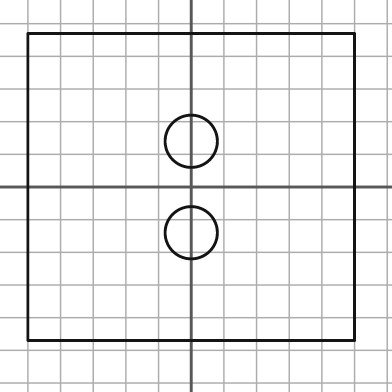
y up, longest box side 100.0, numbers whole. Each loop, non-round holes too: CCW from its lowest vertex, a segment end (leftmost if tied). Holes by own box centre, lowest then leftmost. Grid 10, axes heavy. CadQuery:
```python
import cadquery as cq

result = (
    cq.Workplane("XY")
    .moveTo(-50.0, -47.0)
    .lineTo(50.0, -47.0)
    .lineTo(50.0, 47.0)
    .lineTo(-50.0, 47.0)
    .close()
    .moveTo(0.0, -14.0)
    .circle(8.0)
    .moveTo(0.0, 14.0)
    .circle(8.0)
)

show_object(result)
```